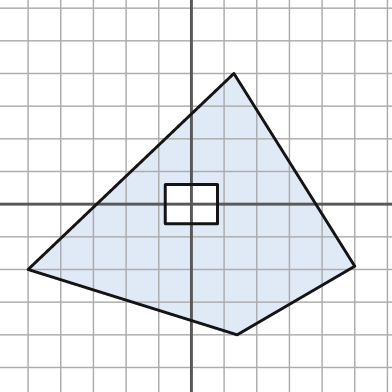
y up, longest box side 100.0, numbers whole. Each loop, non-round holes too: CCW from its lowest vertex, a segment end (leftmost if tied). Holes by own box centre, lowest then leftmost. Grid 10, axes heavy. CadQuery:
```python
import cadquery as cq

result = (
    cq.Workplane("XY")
    .moveTo(14.0, -40.0)
    .lineTo(50.0, -19.0)
    .lineTo(13.0, 40.0)
    .lineTo(-50.0, -20.0)
    .close()
    .moveTo(-8.0, -6.0)
    .lineTo(8.0, -6.0)
    .lineTo(8.0, 6.0)
    .lineTo(-8.0, 6.0)
    .close()
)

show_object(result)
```